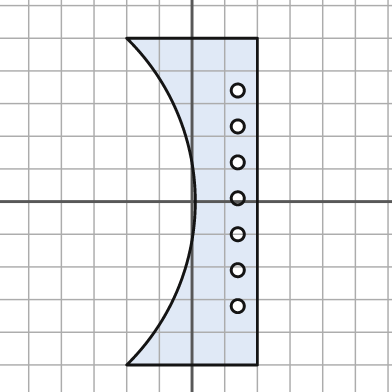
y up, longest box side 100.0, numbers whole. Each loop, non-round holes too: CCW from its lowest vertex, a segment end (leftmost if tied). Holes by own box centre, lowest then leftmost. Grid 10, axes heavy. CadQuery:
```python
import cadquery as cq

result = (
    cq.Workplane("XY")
    .moveTo(-20.0, -50.0)
    .lineTo(20.0, -50.0)
    .lineTo(20.0, 50.0)
    .lineTo(-20.0, 50.0)
    .threePointArc((1.0, 0.0), (-20.0, -50.0))
    .close()
    .moveTo(14.0, -32.0)
    .circle(2.0)
    .moveTo(14.0, -21.0)
    .circle(2.0)
    .moveTo(14.0, -10.0)
    .circle(2.0)
    .moveTo(14.0, 1.0)
    .circle(2.0)
    .moveTo(14.0, 12.0)
    .circle(2.0)
    .moveTo(14.0, 23.0)
    .circle(2.0)
    .moveTo(14.0, 34.0)
    .circle(2.0)
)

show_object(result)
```